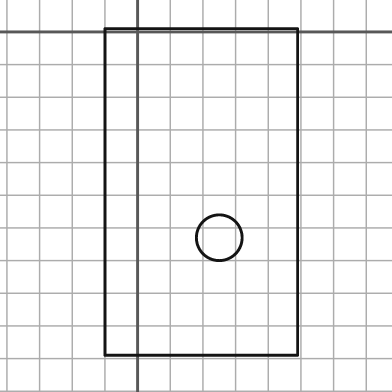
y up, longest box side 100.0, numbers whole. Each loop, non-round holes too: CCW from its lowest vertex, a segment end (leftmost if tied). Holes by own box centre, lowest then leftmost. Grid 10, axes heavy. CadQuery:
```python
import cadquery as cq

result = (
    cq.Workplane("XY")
    .moveTo(-10.0, -99.0)
    .lineTo(49.0, -99.0)
    .lineTo(49.0, 1.0)
    .lineTo(-10.0, 1.0)
    .close()
    .moveTo(25.0, -63.0)
    .circle(7.0)
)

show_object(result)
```